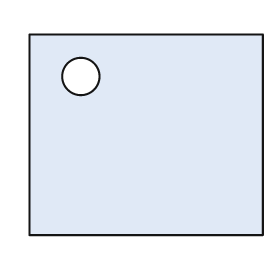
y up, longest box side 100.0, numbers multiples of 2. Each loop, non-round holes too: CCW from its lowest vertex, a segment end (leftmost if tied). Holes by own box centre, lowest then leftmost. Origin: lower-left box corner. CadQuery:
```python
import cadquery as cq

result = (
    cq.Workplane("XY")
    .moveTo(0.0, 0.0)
    .lineTo(100.0, 0.0)
    .lineTo(100.0, 86.0)
    .lineTo(0.0, 86.0)
    .close()
    .moveTo(22.0, 68.0)
    .circle(8.0)
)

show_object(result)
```